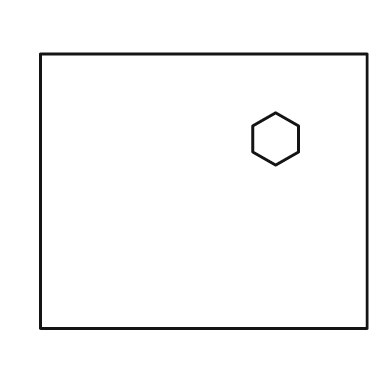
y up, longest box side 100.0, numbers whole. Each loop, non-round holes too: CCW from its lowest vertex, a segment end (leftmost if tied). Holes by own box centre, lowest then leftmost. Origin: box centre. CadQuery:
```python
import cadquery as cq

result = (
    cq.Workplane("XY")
    .moveTo(-50.0, -42.0)
    .lineTo(50.0, -42.0)
    .lineTo(50.0, 42.0)
    .lineTo(-50.0, 42.0)
    .close()
    .moveTo(22.0, 8.0)
    .lineTo(29.0, 12.0)
    .lineTo(29.0, 20.0)
    .lineTo(22.0, 24.0)
    .lineTo(15.0, 20.0)
    .lineTo(15.0, 12.0)
    .close()
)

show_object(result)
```